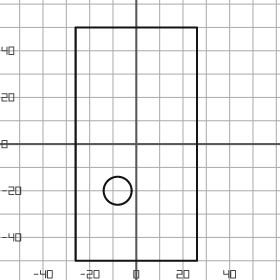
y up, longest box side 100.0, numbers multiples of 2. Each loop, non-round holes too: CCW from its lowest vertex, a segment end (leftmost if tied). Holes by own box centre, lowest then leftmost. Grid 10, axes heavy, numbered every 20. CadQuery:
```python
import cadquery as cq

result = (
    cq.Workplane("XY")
    .moveTo(-26.0, -50.0)
    .lineTo(26.0, -50.0)
    .lineTo(26.0, 50.0)
    .lineTo(-26.0, 50.0)
    .close()
    .moveTo(-8.0, -20.0)
    .circle(6.0)
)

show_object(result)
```